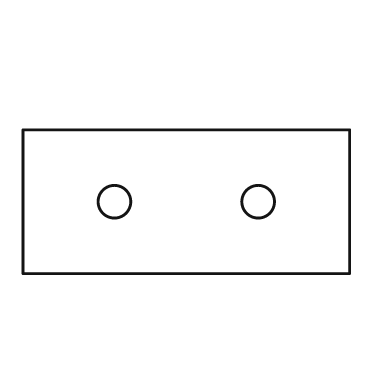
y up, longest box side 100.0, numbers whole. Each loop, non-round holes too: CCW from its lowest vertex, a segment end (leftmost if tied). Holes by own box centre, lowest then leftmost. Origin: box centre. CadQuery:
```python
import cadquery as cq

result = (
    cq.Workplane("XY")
    .moveTo(-50.0, -22.0)
    .lineTo(50.0, -22.0)
    .lineTo(50.0, 22.0)
    .lineTo(-50.0, 22.0)
    .close()
    .moveTo(-22.0, 0.0)
    .circle(5.0)
    .moveTo(22.0, 0.0)
    .circle(5.0)
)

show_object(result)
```